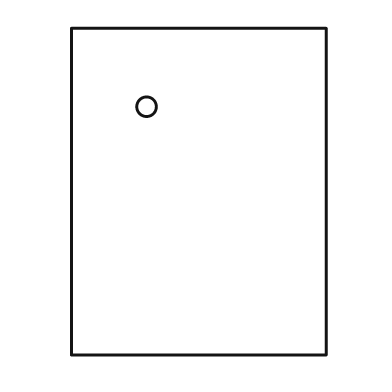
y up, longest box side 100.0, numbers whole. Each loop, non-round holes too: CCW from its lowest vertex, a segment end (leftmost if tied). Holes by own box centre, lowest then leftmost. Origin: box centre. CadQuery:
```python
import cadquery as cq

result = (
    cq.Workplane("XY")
    .moveTo(-39.0, -50.0)
    .lineTo(39.0, -50.0)
    .lineTo(39.0, 50.0)
    .lineTo(-39.0, 50.0)
    .close()
    .moveTo(-16.0, 26.0)
    .circle(3.0)
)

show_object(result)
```